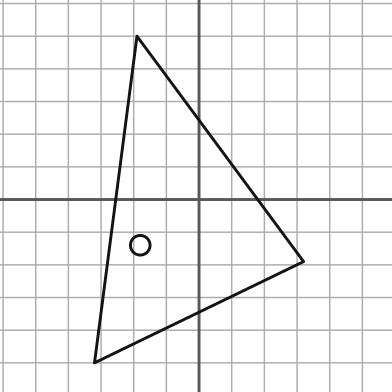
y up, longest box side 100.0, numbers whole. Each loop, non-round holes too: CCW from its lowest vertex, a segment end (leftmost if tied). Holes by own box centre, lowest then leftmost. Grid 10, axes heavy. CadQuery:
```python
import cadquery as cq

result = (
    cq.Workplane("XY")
    .moveTo(-32.0, -50.0)
    .lineTo(32.0, -19.0)
    .lineTo(-19.0, 50.0)
    .close()
    .moveTo(-18.0, -14.0)
    .circle(3.0)
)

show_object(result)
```